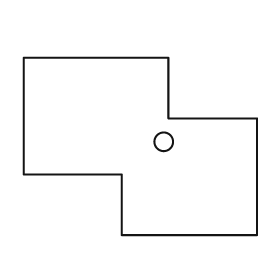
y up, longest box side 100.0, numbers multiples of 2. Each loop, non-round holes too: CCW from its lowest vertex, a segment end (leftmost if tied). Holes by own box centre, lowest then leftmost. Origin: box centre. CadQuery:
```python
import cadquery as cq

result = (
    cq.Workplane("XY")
    .moveTo(-8.0, -38.0)
    .lineTo(50.0, -38.0)
    .lineTo(50.0, 12.0)
    .lineTo(12.0, 12.0)
    .lineTo(12.0, 38.0)
    .lineTo(-50.0, 38.0)
    .lineTo(-50.0, -12.0)
    .lineTo(-8.0, -12.0)
    .close()
    .moveTo(10.0, 2.0)
    .circle(4.0)
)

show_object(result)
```